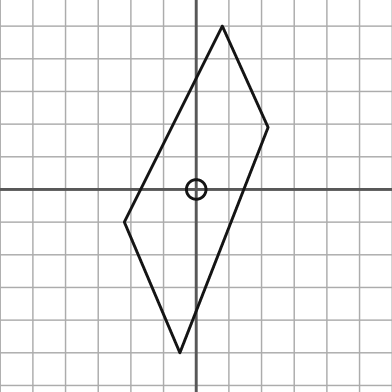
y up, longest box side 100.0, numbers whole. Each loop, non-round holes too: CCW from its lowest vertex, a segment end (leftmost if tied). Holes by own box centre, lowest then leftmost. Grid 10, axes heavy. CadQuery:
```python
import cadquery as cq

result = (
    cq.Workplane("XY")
    .moveTo(-5.0, -50.0)
    .lineTo(22.0, 19.0)
    .lineTo(8.0, 50.0)
    .lineTo(-22.0, -10.0)
    .close()
    .moveTo(0.0, 0.0)
    .circle(3.0)
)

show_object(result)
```